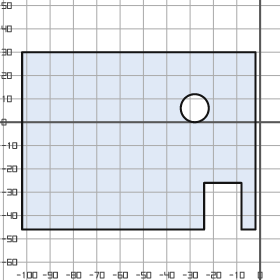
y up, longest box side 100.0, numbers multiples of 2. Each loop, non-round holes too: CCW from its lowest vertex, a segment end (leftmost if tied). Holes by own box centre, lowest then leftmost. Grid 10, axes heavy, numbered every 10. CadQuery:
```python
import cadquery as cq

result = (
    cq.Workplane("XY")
    .moveTo(-102.0, -46.0)
    .lineTo(-24.0, -46.0)
    .lineTo(-24.0, -26.0)
    .lineTo(-8.0, -26.0)
    .lineTo(-8.0, -46.0)
    .lineTo(-2.0, -46.0)
    .lineTo(-2.0, 30.0)
    .lineTo(-102.0, 30.0)
    .close()
    .moveTo(-28.0, 6.0)
    .circle(6.0)
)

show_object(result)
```